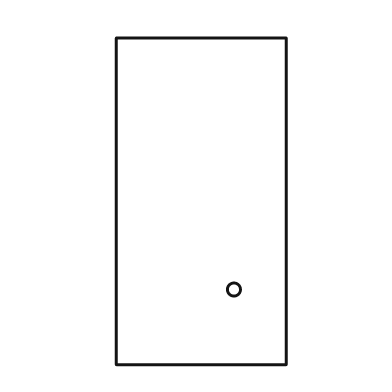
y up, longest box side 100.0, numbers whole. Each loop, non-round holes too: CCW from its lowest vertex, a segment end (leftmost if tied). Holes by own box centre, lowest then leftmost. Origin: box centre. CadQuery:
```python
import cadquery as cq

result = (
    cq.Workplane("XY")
    .moveTo(-26.0, -50.0)
    .lineTo(26.0, -50.0)
    .lineTo(26.0, 50.0)
    .lineTo(-26.0, 50.0)
    .close()
    .moveTo(10.0, -27.0)
    .circle(2.0)
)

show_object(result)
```